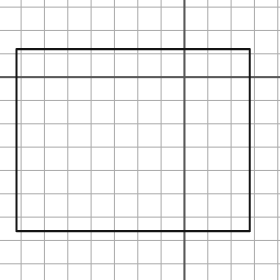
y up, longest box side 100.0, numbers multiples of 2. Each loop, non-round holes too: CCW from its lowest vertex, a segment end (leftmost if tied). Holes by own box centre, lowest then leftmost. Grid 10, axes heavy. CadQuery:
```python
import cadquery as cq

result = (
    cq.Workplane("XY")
    .moveTo(-72.0, -66.0)
    .lineTo(28.0, -66.0)
    .lineTo(28.0, 12.0)
    .lineTo(-72.0, 12.0)
    .close()
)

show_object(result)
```